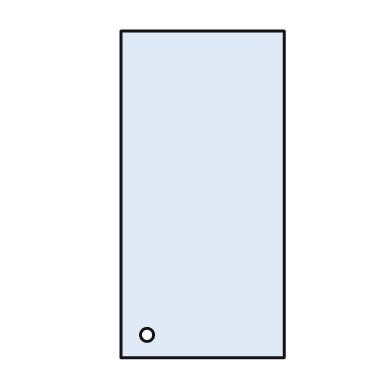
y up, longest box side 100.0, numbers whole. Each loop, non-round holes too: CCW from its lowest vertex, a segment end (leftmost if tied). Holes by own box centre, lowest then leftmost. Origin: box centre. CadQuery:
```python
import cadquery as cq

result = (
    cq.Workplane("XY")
    .moveTo(-25.0, -50.0)
    .lineTo(25.0, -50.0)
    .lineTo(25.0, 50.0)
    .lineTo(-25.0, 50.0)
    .close()
    .moveTo(-17.0, -43.0)
    .circle(2.0)
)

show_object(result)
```